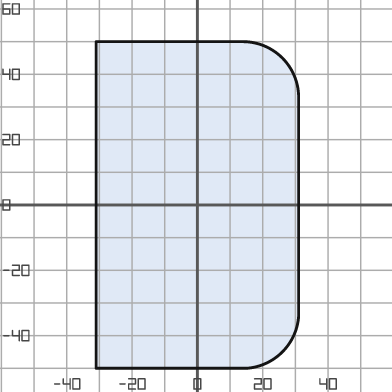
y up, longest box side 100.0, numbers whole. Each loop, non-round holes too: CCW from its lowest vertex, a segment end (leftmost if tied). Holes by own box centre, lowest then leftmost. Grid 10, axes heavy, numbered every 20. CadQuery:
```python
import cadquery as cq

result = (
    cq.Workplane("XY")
    .moveTo(-31.0, -50.0)
    .lineTo(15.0, -50.0)
    .threePointArc((26.0, -45.0), (31.0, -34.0))
    .lineTo(31.0, 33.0)
    .threePointArc((26.0, 45.0), (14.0, 50.0))
    .lineTo(-31.0, 50.0)
    .close()
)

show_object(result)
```